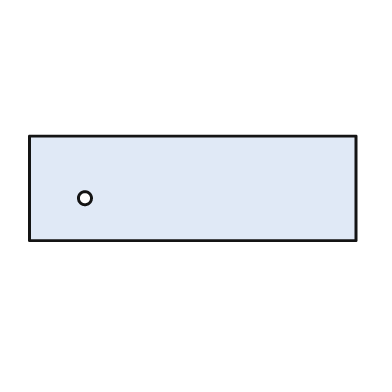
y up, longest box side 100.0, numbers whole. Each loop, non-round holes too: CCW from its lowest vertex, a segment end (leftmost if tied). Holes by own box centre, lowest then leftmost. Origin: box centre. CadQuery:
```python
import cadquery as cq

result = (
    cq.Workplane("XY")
    .moveTo(-50.0, -16.0)
    .lineTo(50.0, -16.0)
    .lineTo(50.0, 16.0)
    .lineTo(-50.0, 16.0)
    .close()
    .moveTo(-33.0, -3.0)
    .circle(2.0)
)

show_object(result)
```